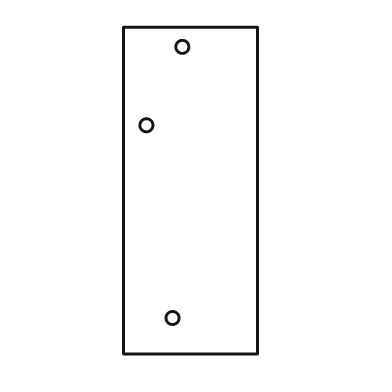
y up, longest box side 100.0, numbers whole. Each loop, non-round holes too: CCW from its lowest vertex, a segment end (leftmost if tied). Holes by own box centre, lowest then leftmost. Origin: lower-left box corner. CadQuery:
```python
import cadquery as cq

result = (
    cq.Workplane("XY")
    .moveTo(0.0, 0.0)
    .lineTo(41.0, 0.0)
    .lineTo(41.0, 100.0)
    .lineTo(0.0, 100.0)
    .close()
    .moveTo(15.0, 11.0)
    .circle(2.0)
    .moveTo(7.0, 70.0)
    .circle(2.0)
    .moveTo(18.0, 94.0)
    .circle(2.0)
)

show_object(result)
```